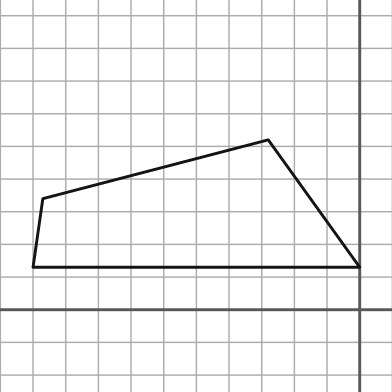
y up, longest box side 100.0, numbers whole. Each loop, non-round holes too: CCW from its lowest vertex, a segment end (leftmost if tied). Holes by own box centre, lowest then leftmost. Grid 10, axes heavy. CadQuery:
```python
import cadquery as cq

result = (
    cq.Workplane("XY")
    .moveTo(-100.0, 13.0)
    .lineTo(0.0, 13.0)
    .lineTo(-28.0, 52.0)
    .lineTo(-97.0, 34.0)
    .close()
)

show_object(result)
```